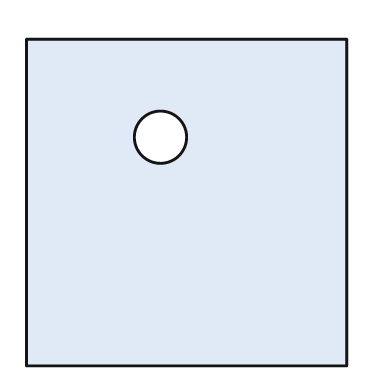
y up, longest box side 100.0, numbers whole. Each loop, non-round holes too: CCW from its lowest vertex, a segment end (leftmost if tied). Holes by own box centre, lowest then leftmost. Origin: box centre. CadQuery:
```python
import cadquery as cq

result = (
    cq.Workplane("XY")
    .moveTo(-49.0, -50.0)
    .lineTo(49.0, -50.0)
    .lineTo(49.0, 50.0)
    .lineTo(-49.0, 50.0)
    .close()
    .moveTo(-8.0, 20.0)
    .circle(8.0)
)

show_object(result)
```